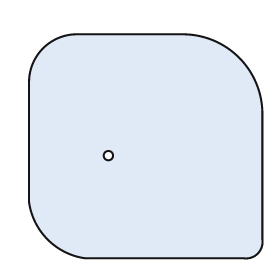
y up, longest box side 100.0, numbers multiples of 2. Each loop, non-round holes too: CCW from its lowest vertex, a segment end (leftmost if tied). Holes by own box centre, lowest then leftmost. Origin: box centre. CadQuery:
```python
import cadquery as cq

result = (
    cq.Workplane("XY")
    .moveTo(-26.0, -48.0)
    .lineTo(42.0, -48.0)
    .threePointArc((48.0, -46.0), (50.0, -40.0))
    .lineTo(50.0, 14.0)
    .threePointArc((40.0, 38.0), (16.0, 48.0))
    .lineTo(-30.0, 48.0)
    .threePointArc((-44.0, 42.0), (-50.0, 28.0))
    .lineTo(-50.0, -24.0)
    .threePointArc((-42.0, -40.0), (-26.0, -48.0))
    .close()
    .moveTo(-16.0, -4.0)
    .circle(2.0)
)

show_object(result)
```